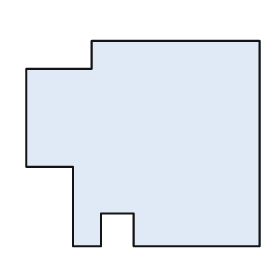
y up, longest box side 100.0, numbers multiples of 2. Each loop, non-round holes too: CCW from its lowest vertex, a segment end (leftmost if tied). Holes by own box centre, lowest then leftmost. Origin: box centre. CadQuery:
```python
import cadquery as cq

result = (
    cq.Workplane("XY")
    .moveTo(-30.0, -44.0)
    .lineTo(-18.0, -44.0)
    .lineTo(-18.0, -30.0)
    .lineTo(-4.0, -30.0)
    .lineTo(-4.0, -44.0)
    .lineTo(50.0, -44.0)
    .lineTo(50.0, 44.0)
    .lineTo(-22.0, 44.0)
    .lineTo(-22.0, 32.0)
    .lineTo(-50.0, 32.0)
    .lineTo(-50.0, -10.0)
    .lineTo(-30.0, -10.0)
    .close()
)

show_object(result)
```